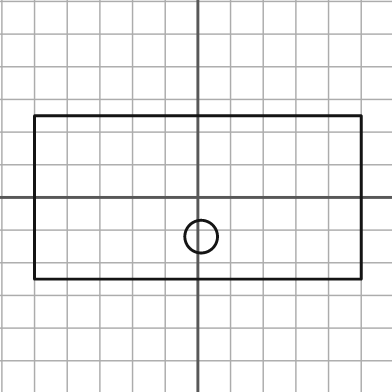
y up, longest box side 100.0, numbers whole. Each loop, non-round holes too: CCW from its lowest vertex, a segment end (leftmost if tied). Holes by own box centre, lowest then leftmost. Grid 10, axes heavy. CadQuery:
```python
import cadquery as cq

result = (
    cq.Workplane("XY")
    .moveTo(-50.0, -25.0)
    .lineTo(50.0, -25.0)
    .lineTo(50.0, 25.0)
    .lineTo(-50.0, 25.0)
    .close()
    .moveTo(1.0, -12.0)
    .circle(5.0)
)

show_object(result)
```